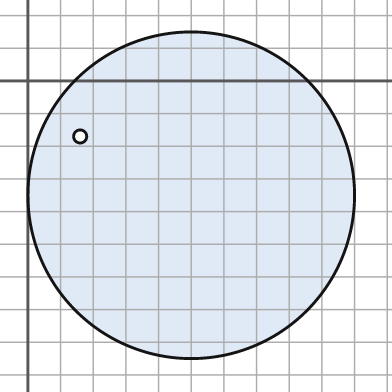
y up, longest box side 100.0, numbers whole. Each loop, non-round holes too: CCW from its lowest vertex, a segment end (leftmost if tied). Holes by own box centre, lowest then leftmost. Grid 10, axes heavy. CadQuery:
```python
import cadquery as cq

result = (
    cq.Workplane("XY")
    .moveTo(50.0, -35.0)
    .circle(50.0)
    .moveTo(16.0, -17.0)
    .circle(2.0)
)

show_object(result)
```